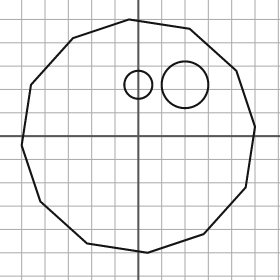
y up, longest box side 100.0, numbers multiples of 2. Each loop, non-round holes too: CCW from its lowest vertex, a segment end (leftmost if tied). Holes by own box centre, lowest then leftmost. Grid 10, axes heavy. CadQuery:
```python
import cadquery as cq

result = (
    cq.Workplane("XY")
    .moveTo(4.0, -50.0)
    .lineTo(28.0, -42.0)
    .lineTo(46.0, -22.0)
    .lineTo(50.0, 4.0)
    .lineTo(42.0, 28.0)
    .lineTo(22.0, 46.0)
    .lineTo(-4.0, 50.0)
    .lineTo(-28.0, 42.0)
    .lineTo(-46.0, 22.0)
    .lineTo(-50.0, -4.0)
    .lineTo(-42.0, -28.0)
    .lineTo(-22.0, -46.0)
    .close()
    .moveTo(0.0, 22.0)
    .circle(6.0)
    .moveTo(20.0, 22.0)
    .circle(10.0)
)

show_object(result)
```